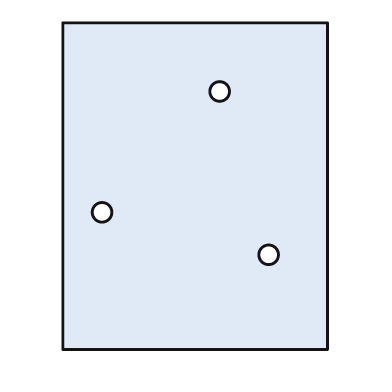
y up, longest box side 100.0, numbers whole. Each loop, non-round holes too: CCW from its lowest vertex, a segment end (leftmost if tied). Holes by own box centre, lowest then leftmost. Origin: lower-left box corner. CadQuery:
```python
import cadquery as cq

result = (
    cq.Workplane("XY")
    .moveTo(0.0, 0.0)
    .lineTo(81.0, 0.0)
    .lineTo(81.0, 100.0)
    .lineTo(0.0, 100.0)
    .close()
    .moveTo(63.0, 29.0)
    .circle(3.0)
    .moveTo(12.0, 42.0)
    .circle(3.0)
    .moveTo(48.0, 79.0)
    .circle(3.0)
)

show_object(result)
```